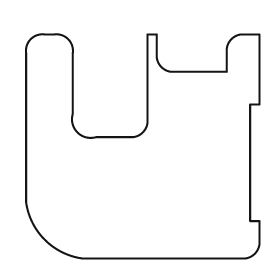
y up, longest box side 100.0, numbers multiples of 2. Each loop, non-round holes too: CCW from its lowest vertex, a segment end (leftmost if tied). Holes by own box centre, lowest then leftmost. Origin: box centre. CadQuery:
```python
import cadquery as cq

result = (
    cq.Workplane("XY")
    .moveTo(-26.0, -48.0)
    .lineTo(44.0, -48.0)
    .threePointArc((48.0, -46.0), (50.0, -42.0))
    .lineTo(50.0, -32.0)
    .lineTo(46.0, -32.0)
    .lineTo(46.0, 18.0)
    .lineTo(50.0, 18.0)
    .lineTo(50.0, 48.0)
    .lineTo(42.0, 48.0)
    .threePointArc((38.0, 46.0), (36.0, 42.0))
    .lineTo(36.0, 32.0)
    .lineTo(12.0, 32.0)
    .threePointArc((8.0, 34.0), (6.0, 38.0))
    .lineTo(6.0, 48.0)
    .lineTo(2.0, 48.0)
    .lineTo(2.0, 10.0)
    .threePointArc((0.0, 6.0), (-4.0, 4.0))
    .lineTo(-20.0, 4.0)
    .threePointArc((-28.0, 6.0), (-30.0, 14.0))
    .lineTo(-30.0, 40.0)
    .threePointArc((-32.0, 46.0), (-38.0, 48.0))
    .lineTo(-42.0, 48.0)
    .threePointArc((-48.0, 46.0), (-50.0, 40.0))
    .lineTo(-50.0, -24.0)
    .threePointArc((-42.0, -40.0), (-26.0, -48.0))
    .close()
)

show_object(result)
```